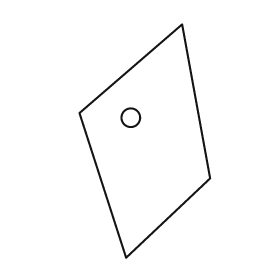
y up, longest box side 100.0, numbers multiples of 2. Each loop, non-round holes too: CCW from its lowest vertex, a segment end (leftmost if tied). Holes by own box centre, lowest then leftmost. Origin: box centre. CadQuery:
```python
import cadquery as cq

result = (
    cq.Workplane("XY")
    .moveTo(-8.0, -50.0)
    .lineTo(28.0, -16.0)
    .lineTo(16.0, 50.0)
    .lineTo(-28.0, 12.0)
    .close()
    .moveTo(-6.0, 10.0)
    .circle(4.0)
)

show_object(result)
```